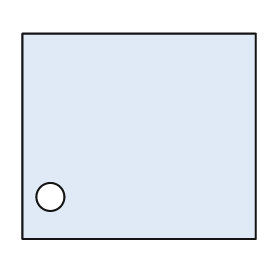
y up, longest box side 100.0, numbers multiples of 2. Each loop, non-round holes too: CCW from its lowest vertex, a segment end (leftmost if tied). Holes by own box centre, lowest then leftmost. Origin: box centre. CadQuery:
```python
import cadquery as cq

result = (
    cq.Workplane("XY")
    .moveTo(-50.0, -44.0)
    .lineTo(50.0, -44.0)
    .lineTo(50.0, 44.0)
    .lineTo(-50.0, 44.0)
    .close()
    .moveTo(-38.0, -26.0)
    .circle(6.0)
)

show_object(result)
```